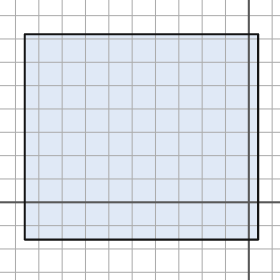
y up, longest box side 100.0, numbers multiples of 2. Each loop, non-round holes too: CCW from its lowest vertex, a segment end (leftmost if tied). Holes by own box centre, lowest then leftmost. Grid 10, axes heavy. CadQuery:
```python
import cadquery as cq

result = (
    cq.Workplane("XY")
    .moveTo(-96.0, -16.0)
    .lineTo(4.0, -16.0)
    .lineTo(4.0, 72.0)
    .lineTo(-96.0, 72.0)
    .close()
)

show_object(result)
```